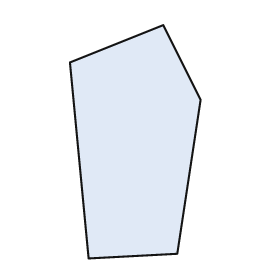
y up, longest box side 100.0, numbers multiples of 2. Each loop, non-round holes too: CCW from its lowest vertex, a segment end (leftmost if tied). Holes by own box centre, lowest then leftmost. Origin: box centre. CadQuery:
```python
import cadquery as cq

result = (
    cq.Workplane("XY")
    .moveTo(-20.0, -50.0)
    .lineTo(18.0, -48.0)
    .lineTo(28.0, 18.0)
    .lineTo(12.0, 50.0)
    .lineTo(-28.0, 34.0)
    .close()
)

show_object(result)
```